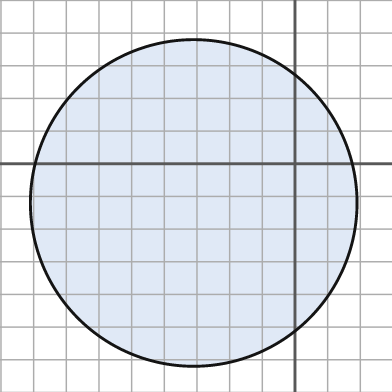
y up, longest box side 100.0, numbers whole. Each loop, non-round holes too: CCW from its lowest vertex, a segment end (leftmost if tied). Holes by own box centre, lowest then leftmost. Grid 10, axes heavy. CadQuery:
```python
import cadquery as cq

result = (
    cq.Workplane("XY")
    .moveTo(-31.0, -12.0)
    .circle(50.0)
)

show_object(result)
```